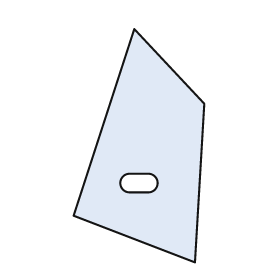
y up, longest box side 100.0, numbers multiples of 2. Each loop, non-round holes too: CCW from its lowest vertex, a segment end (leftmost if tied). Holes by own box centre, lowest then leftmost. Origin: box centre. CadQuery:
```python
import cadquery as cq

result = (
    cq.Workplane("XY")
    .moveTo(24.0, -50.0)
    .lineTo(28.0, 18.0)
    .lineTo(-2.0, 50.0)
    .lineTo(-28.0, -30.0)
    .close()
    .moveTo(-4.0, -20.0)
    .lineTo(4.0, -20.0)
    .threePointArc((8.0, -16.0), (4.0, -12.0))
    .lineTo(-4.0, -12.0)
    .threePointArc((-8.0, -16.0), (-4.0, -20.0))
    .close()
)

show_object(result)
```